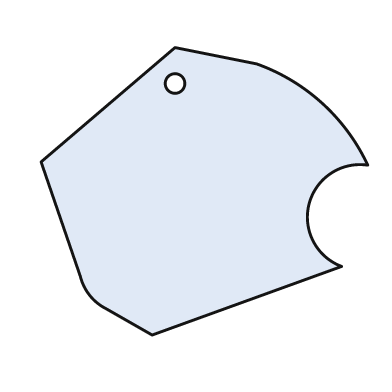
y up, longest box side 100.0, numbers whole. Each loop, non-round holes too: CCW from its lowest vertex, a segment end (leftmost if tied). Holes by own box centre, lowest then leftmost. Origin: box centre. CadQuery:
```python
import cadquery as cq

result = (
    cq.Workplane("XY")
    .moveTo(-16.0, -44.0)
    .lineTo(42.0, -23.0)
    .threePointArc((32.0, -4.0), (50.0, 8.0))
    .threePointArc((36.0, 27.0), (16.0, 39.0))
    .lineTo(-9.0, 44.0)
    .lineTo(-50.0, 9.0)
    .lineTo(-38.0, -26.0)
    .threePointArc((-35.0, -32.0), (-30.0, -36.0))
    .close()
    .moveTo(-9.0, 33.0)
    .circle(3.0)
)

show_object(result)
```